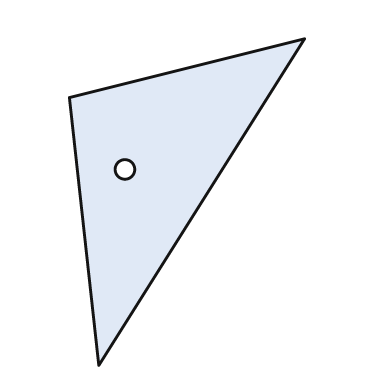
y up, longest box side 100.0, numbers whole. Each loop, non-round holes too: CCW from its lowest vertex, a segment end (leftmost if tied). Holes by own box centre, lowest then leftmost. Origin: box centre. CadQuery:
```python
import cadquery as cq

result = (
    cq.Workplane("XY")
    .moveTo(-27.0, -50.0)
    .lineTo(36.0, 50.0)
    .lineTo(-36.0, 32.0)
    .close()
    .moveTo(-19.0, 10.0)
    .circle(3.0)
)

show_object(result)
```